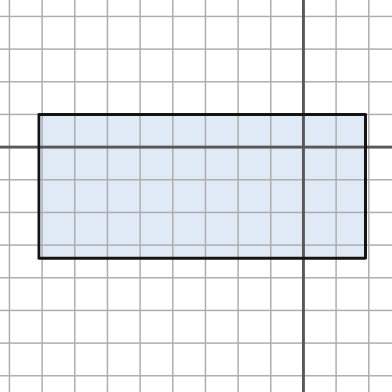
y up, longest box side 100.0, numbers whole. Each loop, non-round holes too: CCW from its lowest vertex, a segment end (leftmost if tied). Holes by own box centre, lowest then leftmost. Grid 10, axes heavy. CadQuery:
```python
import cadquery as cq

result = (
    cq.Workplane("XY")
    .moveTo(-81.0, -34.0)
    .lineTo(19.0, -34.0)
    .lineTo(19.0, 10.0)
    .lineTo(-81.0, 10.0)
    .close()
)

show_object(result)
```